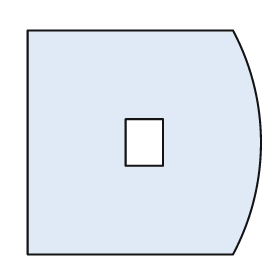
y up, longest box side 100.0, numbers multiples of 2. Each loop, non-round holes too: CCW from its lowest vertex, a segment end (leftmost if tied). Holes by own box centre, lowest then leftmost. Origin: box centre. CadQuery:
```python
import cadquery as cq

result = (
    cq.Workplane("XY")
    .moveTo(-50.0, -48.0)
    .lineTo(38.0, -48.0)
    .threePointArc((50.0, 0.0), (38.0, 48.0))
    .lineTo(-50.0, 48.0)
    .close()
    .moveTo(-8.0, -10.0)
    .lineTo(8.0, -10.0)
    .lineTo(8.0, 10.0)
    .lineTo(-8.0, 10.0)
    .close()
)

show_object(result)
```